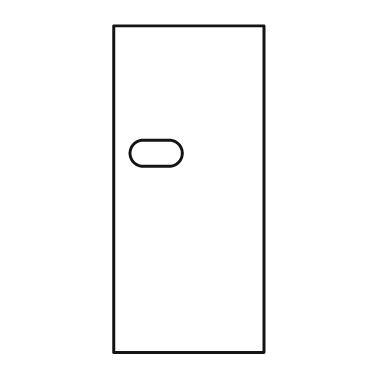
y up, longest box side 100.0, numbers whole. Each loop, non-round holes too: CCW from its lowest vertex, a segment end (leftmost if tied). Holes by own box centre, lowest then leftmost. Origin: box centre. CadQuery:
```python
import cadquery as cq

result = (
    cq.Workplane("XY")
    .moveTo(-23.0, -50.0)
    .lineTo(23.0, -50.0)
    .lineTo(23.0, 50.0)
    .lineTo(-23.0, 50.0)
    .close()
    .moveTo(-14.0, 7.0)
    .lineTo(-6.0, 7.0)
    .threePointArc((-2.0, 11.0), (-6.0, 15.0))
    .lineTo(-14.0, 15.0)
    .threePointArc((-18.0, 11.0), (-14.0, 7.0))
    .close()
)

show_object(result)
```